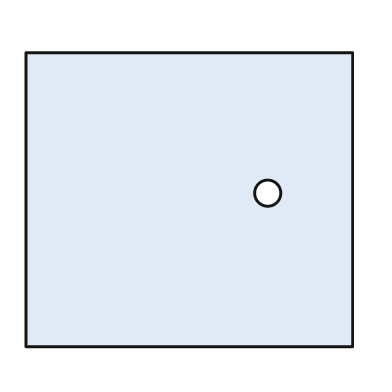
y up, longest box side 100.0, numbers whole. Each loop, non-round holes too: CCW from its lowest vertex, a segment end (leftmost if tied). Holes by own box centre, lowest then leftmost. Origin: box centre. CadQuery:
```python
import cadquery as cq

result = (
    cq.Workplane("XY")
    .moveTo(-50.0, -45.0)
    .lineTo(50.0, -45.0)
    .lineTo(50.0, 45.0)
    .lineTo(-50.0, 45.0)
    .close()
    .moveTo(24.0, 2.0)
    .circle(4.0)
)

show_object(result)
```